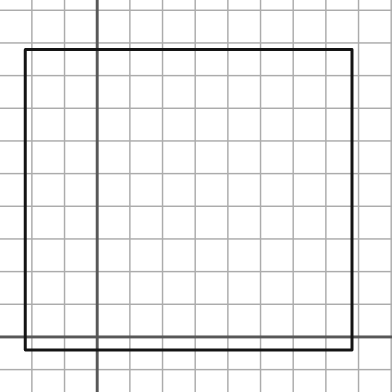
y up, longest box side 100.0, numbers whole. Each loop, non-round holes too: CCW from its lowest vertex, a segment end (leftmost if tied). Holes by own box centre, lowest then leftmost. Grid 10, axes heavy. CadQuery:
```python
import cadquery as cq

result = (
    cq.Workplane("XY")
    .moveTo(-22.0, -4.0)
    .lineTo(78.0, -4.0)
    .lineTo(78.0, 88.0)
    .lineTo(-22.0, 88.0)
    .close()
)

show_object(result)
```